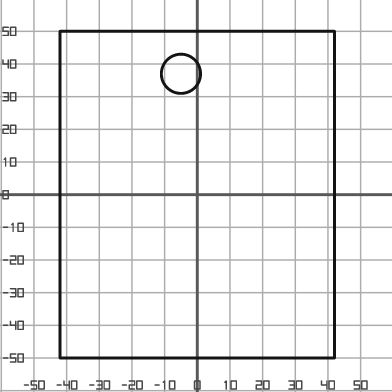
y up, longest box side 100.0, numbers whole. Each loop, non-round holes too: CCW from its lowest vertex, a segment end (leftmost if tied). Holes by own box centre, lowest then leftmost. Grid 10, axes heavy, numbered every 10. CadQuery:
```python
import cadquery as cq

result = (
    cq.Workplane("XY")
    .moveTo(-42.0, -50.0)
    .lineTo(42.0, -50.0)
    .lineTo(42.0, 50.0)
    .lineTo(-42.0, 50.0)
    .close()
    .moveTo(-5.0, 37.0)
    .circle(6.0)
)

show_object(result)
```